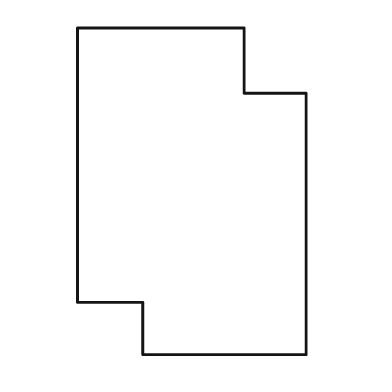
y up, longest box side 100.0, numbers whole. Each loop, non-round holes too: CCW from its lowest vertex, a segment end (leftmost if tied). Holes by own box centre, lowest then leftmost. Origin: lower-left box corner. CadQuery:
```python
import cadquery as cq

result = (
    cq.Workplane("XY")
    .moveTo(20.0, 0.0)
    .lineTo(70.0, 0.0)
    .lineTo(70.0, 80.0)
    .lineTo(51.0, 80.0)
    .lineTo(51.0, 100.0)
    .lineTo(0.0, 100.0)
    .lineTo(0.0, 16.0)
    .lineTo(20.0, 16.0)
    .close()
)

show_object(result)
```